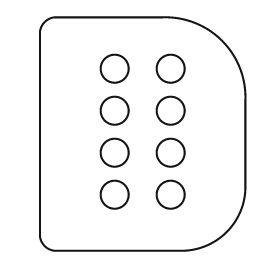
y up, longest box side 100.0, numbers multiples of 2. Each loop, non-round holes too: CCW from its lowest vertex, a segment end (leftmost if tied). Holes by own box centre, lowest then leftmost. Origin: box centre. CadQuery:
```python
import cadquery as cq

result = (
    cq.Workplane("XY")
    .moveTo(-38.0, -50.0)
    .lineTo(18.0, -50.0)
    .threePointArc((36.0, -42.0), (44.0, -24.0))
    .lineTo(44.0, 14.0)
    .threePointArc((34.0, 40.0), (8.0, 50.0))
    .lineTo(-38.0, 50.0)
    .threePointArc((-42.0, 48.0), (-44.0, 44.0))
    .lineTo(-44.0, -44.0)
    .threePointArc((-42.0, -48.0), (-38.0, -50.0))
    .close()
    .moveTo(-12.0, -26.0)
    .circle(6.0)
    .moveTo(12.0, -26.0)
    .circle(6.0)
    .moveTo(-12.0, -8.0)
    .circle(6.0)
    .moveTo(12.0, -8.0)
    .circle(6.0)
    .moveTo(-12.0, 10.0)
    .circle(6.0)
    .moveTo(12.0, 10.0)
    .circle(6.0)
    .moveTo(-12.0, 28.0)
    .circle(6.0)
    .moveTo(12.0, 28.0)
    .circle(6.0)
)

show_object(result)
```